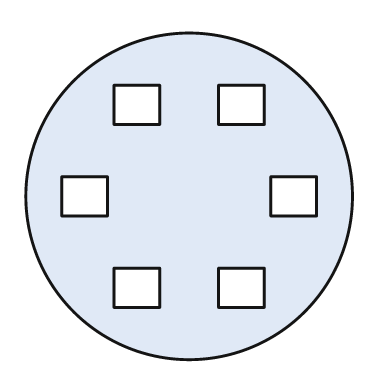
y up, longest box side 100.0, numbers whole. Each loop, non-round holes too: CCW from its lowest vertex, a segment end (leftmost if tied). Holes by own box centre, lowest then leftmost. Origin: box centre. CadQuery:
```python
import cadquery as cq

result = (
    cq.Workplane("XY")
    .moveTo(0.0, 0.0)
    .circle(50.0)
    .moveTo(-23.0, -34.0)
    .lineTo(-9.0, -34.0)
    .lineTo(-9.0, -22.0)
    .lineTo(-23.0, -22.0)
    .close()
    .moveTo(9.0, -34.0)
    .lineTo(23.0, -34.0)
    .lineTo(23.0, -22.0)
    .lineTo(9.0, -22.0)
    .close()
    .moveTo(-39.0, -6.0)
    .lineTo(-25.0, -6.0)
    .lineTo(-25.0, 6.0)
    .lineTo(-39.0, 6.0)
    .close()
    .moveTo(25.0, -6.0)
    .lineTo(39.0, -6.0)
    .lineTo(39.0, 6.0)
    .lineTo(25.0, 6.0)
    .close()
    .moveTo(-23.0, 22.0)
    .lineTo(-9.0, 22.0)
    .lineTo(-9.0, 34.0)
    .lineTo(-23.0, 34.0)
    .close()
    .moveTo(9.0, 22.0)
    .lineTo(23.0, 22.0)
    .lineTo(23.0, 34.0)
    .lineTo(9.0, 34.0)
    .close()
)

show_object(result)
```